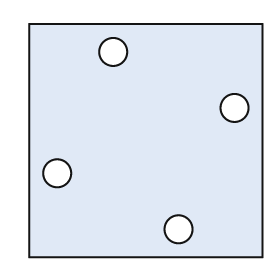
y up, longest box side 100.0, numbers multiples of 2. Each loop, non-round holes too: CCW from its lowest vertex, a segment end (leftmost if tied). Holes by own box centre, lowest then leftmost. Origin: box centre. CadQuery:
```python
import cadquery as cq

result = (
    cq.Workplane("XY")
    .moveTo(-50.0, -50.0)
    .lineTo(50.0, -50.0)
    .lineTo(50.0, 50.0)
    .lineTo(-50.0, 50.0)
    .close()
    .moveTo(14.0, -38.0)
    .circle(6.0)
    .moveTo(-38.0, -14.0)
    .circle(6.0)
    .moveTo(38.0, 14.0)
    .circle(6.0)
    .moveTo(-14.0, 38.0)
    .circle(6.0)
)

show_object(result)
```